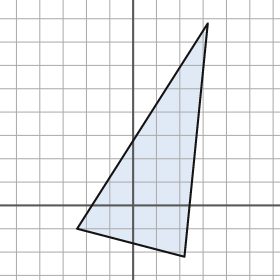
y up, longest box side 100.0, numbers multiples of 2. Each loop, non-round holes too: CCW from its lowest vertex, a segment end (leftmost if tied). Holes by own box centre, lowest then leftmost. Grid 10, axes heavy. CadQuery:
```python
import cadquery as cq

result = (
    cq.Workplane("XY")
    .moveTo(22.0, -22.0)
    .lineTo(32.0, 78.0)
    .lineTo(-24.0, -10.0)
    .close()
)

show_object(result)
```